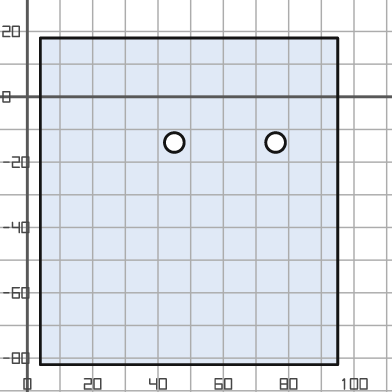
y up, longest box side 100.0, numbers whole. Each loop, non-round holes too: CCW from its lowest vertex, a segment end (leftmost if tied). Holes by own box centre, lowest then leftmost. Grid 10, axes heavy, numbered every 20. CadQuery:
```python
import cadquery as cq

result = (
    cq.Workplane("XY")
    .moveTo(4.0, -82.0)
    .lineTo(95.0, -82.0)
    .lineTo(95.0, 18.0)
    .lineTo(4.0, 18.0)
    .close()
    .moveTo(45.0, -14.0)
    .circle(3.0)
    .moveTo(76.0, -14.0)
    .circle(3.0)
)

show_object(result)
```